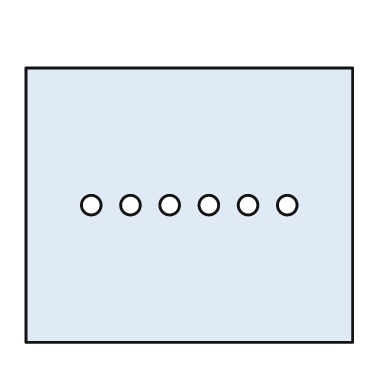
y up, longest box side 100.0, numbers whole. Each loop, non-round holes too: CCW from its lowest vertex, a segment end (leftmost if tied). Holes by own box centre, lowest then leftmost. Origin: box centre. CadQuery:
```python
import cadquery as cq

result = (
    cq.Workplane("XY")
    .moveTo(-50.0, -42.0)
    .lineTo(50.0, -42.0)
    .lineTo(50.0, 42.0)
    .lineTo(-50.0, 42.0)
    .close()
    .moveTo(-30.0, 0.0)
    .circle(3.0)
    .moveTo(-18.0, 0.0)
    .circle(3.0)
    .moveTo(-6.0, 0.0)
    .circle(3.0)
    .moveTo(6.0, 0.0)
    .circle(3.0)
    .moveTo(18.0, 0.0)
    .circle(3.0)
    .moveTo(30.0, 0.0)
    .circle(3.0)
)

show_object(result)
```